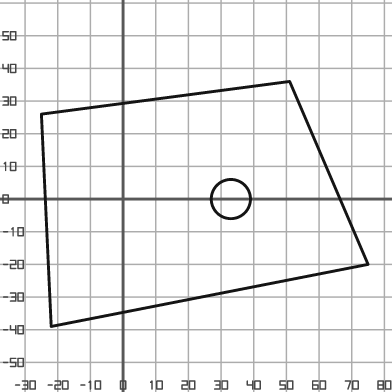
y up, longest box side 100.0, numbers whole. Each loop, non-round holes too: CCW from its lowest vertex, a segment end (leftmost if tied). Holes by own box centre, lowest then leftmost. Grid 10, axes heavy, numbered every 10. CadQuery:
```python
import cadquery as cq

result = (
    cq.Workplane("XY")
    .moveTo(-22.0, -39.0)
    .lineTo(75.0, -20.0)
    .lineTo(51.0, 36.0)
    .lineTo(-25.0, 26.0)
    .close()
    .moveTo(33.0, 0.0)
    .circle(6.0)
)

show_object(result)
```